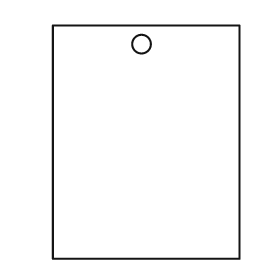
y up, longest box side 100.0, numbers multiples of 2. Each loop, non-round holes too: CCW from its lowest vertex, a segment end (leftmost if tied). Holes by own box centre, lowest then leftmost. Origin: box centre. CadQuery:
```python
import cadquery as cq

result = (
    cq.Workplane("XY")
    .moveTo(-40.0, -50.0)
    .lineTo(40.0, -50.0)
    .lineTo(40.0, 50.0)
    .lineTo(-40.0, 50.0)
    .close()
    .moveTo(-2.0, 42.0)
    .circle(4.0)
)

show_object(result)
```